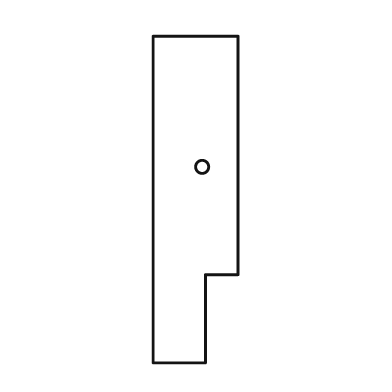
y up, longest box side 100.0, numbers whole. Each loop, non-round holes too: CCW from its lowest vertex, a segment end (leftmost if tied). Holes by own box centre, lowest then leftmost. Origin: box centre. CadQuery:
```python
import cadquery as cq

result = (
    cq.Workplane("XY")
    .moveTo(-13.0, -50.0)
    .lineTo(3.0, -50.0)
    .lineTo(3.0, -23.0)
    .lineTo(13.0, -23.0)
    .lineTo(13.0, 50.0)
    .lineTo(-13.0, 50.0)
    .close()
    .moveTo(2.0, 10.0)
    .circle(2.0)
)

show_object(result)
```